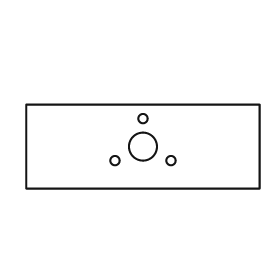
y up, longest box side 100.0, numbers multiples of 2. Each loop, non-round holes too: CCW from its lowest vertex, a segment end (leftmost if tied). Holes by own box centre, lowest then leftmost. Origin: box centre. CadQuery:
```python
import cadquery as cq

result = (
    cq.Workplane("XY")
    .moveTo(-50.0, -18.0)
    .lineTo(50.0, -18.0)
    .lineTo(50.0, 18.0)
    .lineTo(-50.0, 18.0)
    .close()
    .moveTo(-12.0, -6.0)
    .circle(2.0)
    .moveTo(12.0, -6.0)
    .circle(2.0)
    .moveTo(0.0, 0.0)
    .circle(6.0)
    .moveTo(0.0, 12.0)
    .circle(2.0)
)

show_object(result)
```